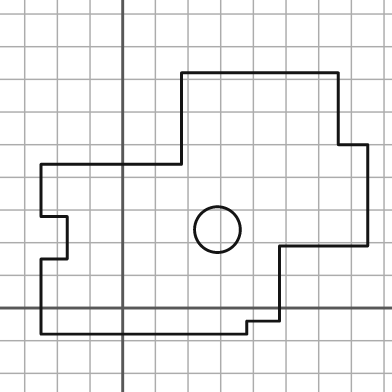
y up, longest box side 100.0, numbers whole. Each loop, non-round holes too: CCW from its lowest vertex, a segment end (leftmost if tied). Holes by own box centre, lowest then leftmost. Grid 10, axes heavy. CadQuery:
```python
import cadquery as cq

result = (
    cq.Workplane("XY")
    .moveTo(-25.0, -8.0)
    .lineTo(38.0, -8.0)
    .lineTo(38.0, -4.0)
    .lineTo(48.0, -4.0)
    .lineTo(48.0, 19.0)
    .lineTo(75.0, 19.0)
    .lineTo(75.0, 50.0)
    .lineTo(66.0, 50.0)
    .lineTo(66.0, 72.0)
    .lineTo(18.0, 72.0)
    .lineTo(18.0, 44.0)
    .lineTo(-25.0, 44.0)
    .lineTo(-25.0, 28.0)
    .lineTo(-17.0, 28.0)
    .lineTo(-17.0, 15.0)
    .lineTo(-25.0, 15.0)
    .close()
    .moveTo(29.0, 24.0)
    .circle(7.0)
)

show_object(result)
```